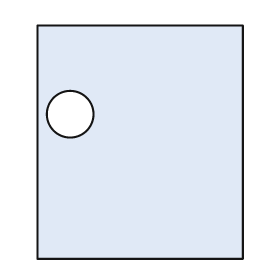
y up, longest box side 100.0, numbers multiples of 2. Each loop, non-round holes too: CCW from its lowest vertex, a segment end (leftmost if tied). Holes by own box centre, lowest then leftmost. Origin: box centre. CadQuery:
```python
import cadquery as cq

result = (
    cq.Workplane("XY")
    .moveTo(-44.0, -50.0)
    .lineTo(44.0, -50.0)
    .lineTo(44.0, 50.0)
    .lineTo(-44.0, 50.0)
    .close()
    .moveTo(-30.0, 12.0)
    .circle(10.0)
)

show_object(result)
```